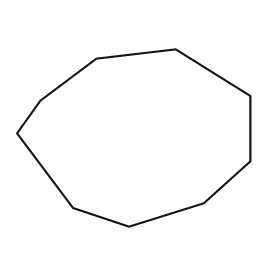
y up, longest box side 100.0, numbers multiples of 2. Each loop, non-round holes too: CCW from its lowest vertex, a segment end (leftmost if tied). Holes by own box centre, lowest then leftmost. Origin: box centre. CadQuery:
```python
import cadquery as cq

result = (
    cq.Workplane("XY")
    .moveTo(-2.0, -38.0)
    .lineTo(30.0, -28.0)
    .lineTo(50.0, -10.0)
    .lineTo(50.0, 18.0)
    .lineTo(18.0, 38.0)
    .lineTo(-16.0, 34.0)
    .lineTo(-40.0, 16.0)
    .lineTo(-50.0, 2.0)
    .lineTo(-26.0, -30.0)
    .close()
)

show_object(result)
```